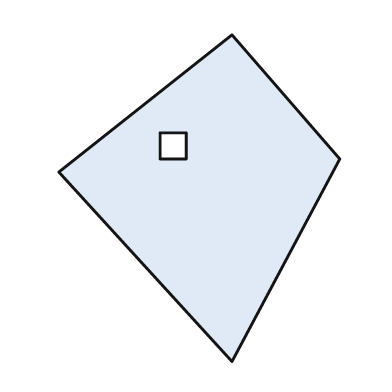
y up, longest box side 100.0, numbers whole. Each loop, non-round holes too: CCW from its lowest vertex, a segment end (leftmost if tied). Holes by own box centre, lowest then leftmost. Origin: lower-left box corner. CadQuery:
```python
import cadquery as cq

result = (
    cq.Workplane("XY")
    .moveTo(53.0, 0.0)
    .lineTo(86.0, 62.0)
    .lineTo(53.0, 100.0)
    .lineTo(0.0, 58.0)
    .close()
    .moveTo(31.0, 62.0)
    .lineTo(39.0, 62.0)
    .lineTo(39.0, 70.0)
    .lineTo(31.0, 70.0)
    .close()
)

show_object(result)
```